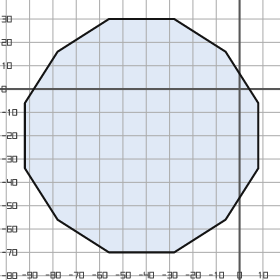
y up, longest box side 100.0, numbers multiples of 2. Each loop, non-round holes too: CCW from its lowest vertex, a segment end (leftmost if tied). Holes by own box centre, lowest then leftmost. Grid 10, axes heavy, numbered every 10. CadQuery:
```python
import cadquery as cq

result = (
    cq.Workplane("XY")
    .moveTo(-56.0, -70.0)
    .lineTo(-28.0, -70.0)
    .lineTo(-6.0, -56.0)
    .lineTo(8.0, -34.0)
    .lineTo(8.0, -6.0)
    .lineTo(-6.0, 16.0)
    .lineTo(-28.0, 30.0)
    .lineTo(-56.0, 30.0)
    .lineTo(-78.0, 16.0)
    .lineTo(-92.0, -6.0)
    .lineTo(-92.0, -34.0)
    .lineTo(-78.0, -56.0)
    .close()
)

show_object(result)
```